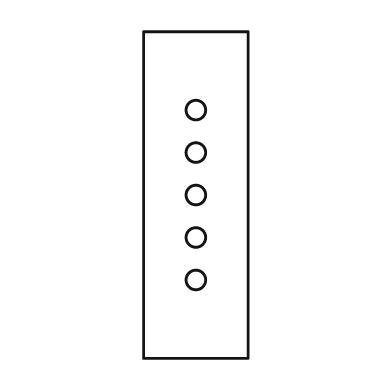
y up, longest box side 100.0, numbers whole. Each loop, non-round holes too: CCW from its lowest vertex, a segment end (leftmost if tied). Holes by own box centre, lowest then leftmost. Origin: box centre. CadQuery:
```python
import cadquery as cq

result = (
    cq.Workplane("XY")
    .moveTo(-16.0, -50.0)
    .lineTo(16.0, -50.0)
    .lineTo(16.0, 50.0)
    .lineTo(-16.0, 50.0)
    .close()
    .moveTo(0.0, -26.0)
    .circle(3.0)
    .moveTo(0.0, -13.0)
    .circle(3.0)
    .moveTo(0.0, 0.0)
    .circle(3.0)
    .moveTo(0.0, 13.0)
    .circle(3.0)
    .moveTo(0.0, 26.0)
    .circle(3.0)
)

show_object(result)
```